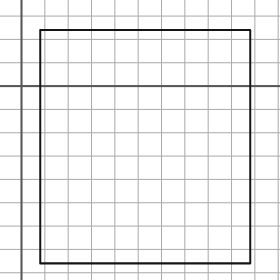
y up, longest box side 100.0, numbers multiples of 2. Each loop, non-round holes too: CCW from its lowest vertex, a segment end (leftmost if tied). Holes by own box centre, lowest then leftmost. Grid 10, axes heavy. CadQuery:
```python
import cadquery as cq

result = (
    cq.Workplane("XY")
    .moveTo(8.0, -76.0)
    .lineTo(98.0, -76.0)
    .lineTo(98.0, 24.0)
    .lineTo(8.0, 24.0)
    .close()
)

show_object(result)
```